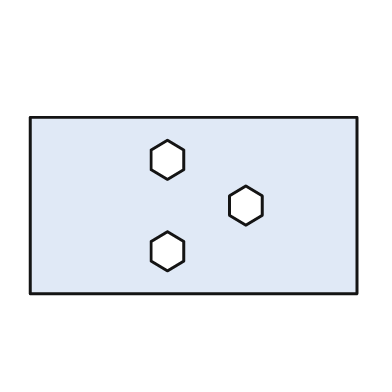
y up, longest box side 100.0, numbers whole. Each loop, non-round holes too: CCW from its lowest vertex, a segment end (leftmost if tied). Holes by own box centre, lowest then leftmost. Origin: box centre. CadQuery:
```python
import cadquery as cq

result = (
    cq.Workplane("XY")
    .moveTo(-50.0, -27.0)
    .lineTo(50.0, -27.0)
    .lineTo(50.0, 27.0)
    .lineTo(-50.0, 27.0)
    .close()
    .moveTo(-8.0, -20.0)
    .lineTo(-3.0, -17.0)
    .lineTo(-3.0, -11.0)
    .lineTo(-8.0, -8.0)
    .lineTo(-13.0, -11.0)
    .lineTo(-13.0, -17.0)
    .close()
    .moveTo(16.0, -6.0)
    .lineTo(21.0, -3.0)
    .lineTo(21.0, 3.0)
    .lineTo(16.0, 6.0)
    .lineTo(11.0, 3.0)
    .lineTo(11.0, -3.0)
    .close()
    .moveTo(-8.0, 8.0)
    .lineTo(-3.0, 11.0)
    .lineTo(-3.0, 17.0)
    .lineTo(-8.0, 20.0)
    .lineTo(-13.0, 17.0)
    .lineTo(-13.0, 11.0)
    .close()
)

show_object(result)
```